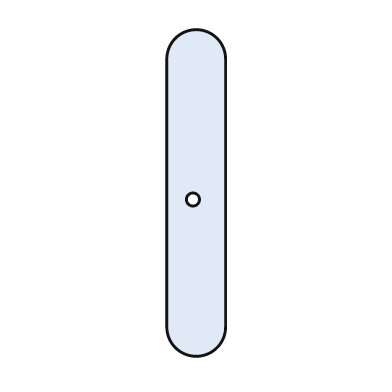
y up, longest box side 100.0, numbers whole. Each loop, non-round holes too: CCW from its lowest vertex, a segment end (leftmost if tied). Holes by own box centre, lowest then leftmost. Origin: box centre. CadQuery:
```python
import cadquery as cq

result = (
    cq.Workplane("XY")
    .moveTo(-9.0, -41.0)
    .threePointArc((0.0, -50.0), (9.0, -41.0))
    .lineTo(9.0, 41.0)
    .threePointArc((0.0, 50.0), (-9.0, 41.0))
    .close()
    .moveTo(-1.0, -2.0)
    .circle(2.0)
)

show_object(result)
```